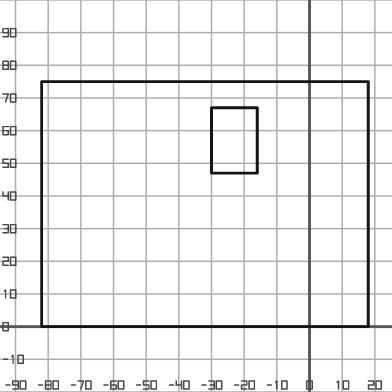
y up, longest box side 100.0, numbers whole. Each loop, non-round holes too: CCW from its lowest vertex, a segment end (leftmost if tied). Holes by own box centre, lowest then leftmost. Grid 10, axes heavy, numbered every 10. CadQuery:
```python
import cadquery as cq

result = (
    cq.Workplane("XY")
    .moveTo(-82.0, 0.0)
    .lineTo(18.0, 0.0)
    .lineTo(18.0, 75.0)
    .lineTo(-82.0, 75.0)
    .close()
    .moveTo(-30.0, 47.0)
    .lineTo(-16.0, 47.0)
    .lineTo(-16.0, 67.0)
    .lineTo(-30.0, 67.0)
    .close()
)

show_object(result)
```